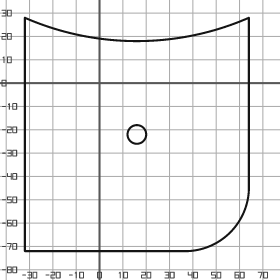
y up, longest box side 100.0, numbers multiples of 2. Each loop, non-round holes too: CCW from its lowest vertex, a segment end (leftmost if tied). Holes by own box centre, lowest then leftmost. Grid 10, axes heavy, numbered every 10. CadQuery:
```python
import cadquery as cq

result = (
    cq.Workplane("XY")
    .moveTo(-32.0, -72.0)
    .lineTo(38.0, -72.0)
    .threePointArc((56.0, -64.0), (64.0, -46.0))
    .lineTo(64.0, 28.0)
    .threePointArc((16.0, 18.0), (-32.0, 28.0))
    .close()
    .moveTo(16.0, -22.0)
    .circle(4.0)
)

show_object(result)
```